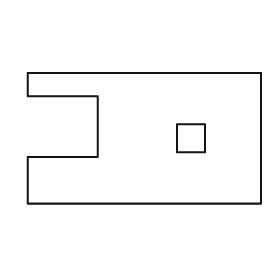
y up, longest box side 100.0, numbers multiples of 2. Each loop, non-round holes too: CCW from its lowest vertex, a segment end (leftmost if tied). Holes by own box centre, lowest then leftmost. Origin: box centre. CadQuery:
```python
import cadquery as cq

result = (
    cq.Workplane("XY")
    .moveTo(-50.0, -28.0)
    .lineTo(50.0, -28.0)
    .lineTo(50.0, 28.0)
    .lineTo(-50.0, 28.0)
    .lineTo(-50.0, 18.0)
    .lineTo(-20.0, 18.0)
    .lineTo(-20.0, -8.0)
    .lineTo(-50.0, -8.0)
    .close()
    .moveTo(14.0, -6.0)
    .lineTo(26.0, -6.0)
    .lineTo(26.0, 6.0)
    .lineTo(14.0, 6.0)
    .close()
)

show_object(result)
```